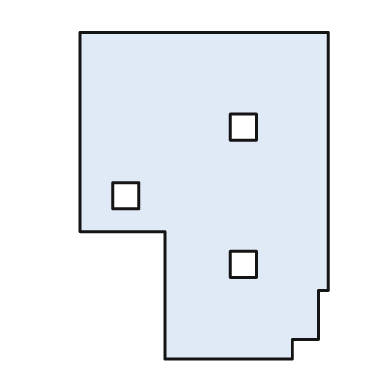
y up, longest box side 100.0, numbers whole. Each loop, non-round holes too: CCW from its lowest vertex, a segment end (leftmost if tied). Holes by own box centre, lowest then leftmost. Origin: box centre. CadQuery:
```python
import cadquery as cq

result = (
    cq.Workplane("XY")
    .moveTo(-12.0, -50.0)
    .lineTo(27.0, -50.0)
    .lineTo(27.0, -44.0)
    .lineTo(35.0, -44.0)
    .lineTo(35.0, -29.0)
    .lineTo(38.0, -29.0)
    .lineTo(38.0, 50.0)
    .lineTo(-38.0, 50.0)
    .lineTo(-38.0, -11.0)
    .lineTo(-12.0, -11.0)
    .close()
    .moveTo(8.0, -25.0)
    .lineTo(16.0, -25.0)
    .lineTo(16.0, -17.0)
    .lineTo(8.0, -17.0)
    .close()
    .moveTo(-28.0, -4.0)
    .lineTo(-20.0, -4.0)
    .lineTo(-20.0, 4.0)
    .lineTo(-28.0, 4.0)
    .close()
    .moveTo(8.0, 17.0)
    .lineTo(16.0, 17.0)
    .lineTo(16.0, 25.0)
    .lineTo(8.0, 25.0)
    .close()
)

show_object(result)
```